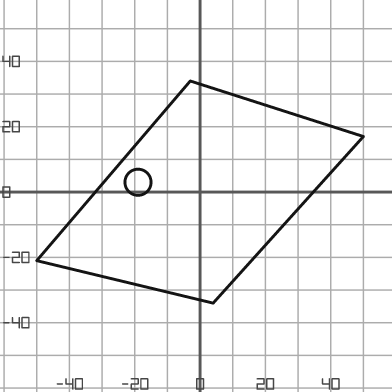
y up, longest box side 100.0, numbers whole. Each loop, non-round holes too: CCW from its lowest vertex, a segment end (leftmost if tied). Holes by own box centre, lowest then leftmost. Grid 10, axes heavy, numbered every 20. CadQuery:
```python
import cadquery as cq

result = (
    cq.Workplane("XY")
    .moveTo(4.0, -34.0)
    .lineTo(50.0, 17.0)
    .lineTo(-3.0, 34.0)
    .lineTo(-50.0, -21.0)
    .close()
    .moveTo(-19.0, 3.0)
    .circle(4.0)
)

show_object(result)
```